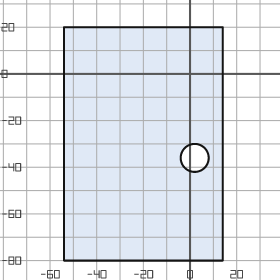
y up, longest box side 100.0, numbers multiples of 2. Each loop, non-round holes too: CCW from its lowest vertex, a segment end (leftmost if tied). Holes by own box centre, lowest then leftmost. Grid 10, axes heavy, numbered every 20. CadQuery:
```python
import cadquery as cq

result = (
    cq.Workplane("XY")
    .moveTo(-54.0, -80.0)
    .lineTo(14.0, -80.0)
    .lineTo(14.0, 20.0)
    .lineTo(-54.0, 20.0)
    .close()
    .moveTo(2.0, -36.0)
    .circle(6.0)
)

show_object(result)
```